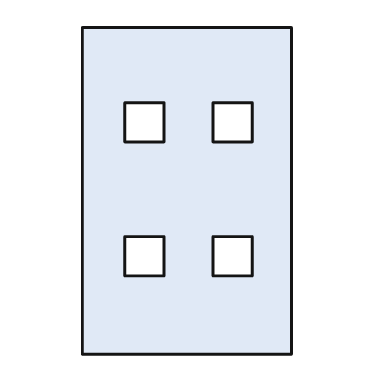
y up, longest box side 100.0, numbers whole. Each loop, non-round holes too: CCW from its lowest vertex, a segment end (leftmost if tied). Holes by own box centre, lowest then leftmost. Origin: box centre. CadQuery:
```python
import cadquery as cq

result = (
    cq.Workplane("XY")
    .moveTo(-32.0, -50.0)
    .lineTo(32.0, -50.0)
    .lineTo(32.0, 50.0)
    .lineTo(-32.0, 50.0)
    .close()
    .moveTo(-19.0, -26.0)
    .lineTo(-7.0, -26.0)
    .lineTo(-7.0, -14.0)
    .lineTo(-19.0, -14.0)
    .close()
    .moveTo(8.0, -26.0)
    .lineTo(20.0, -26.0)
    .lineTo(20.0, -14.0)
    .lineTo(8.0, -14.0)
    .close()
    .moveTo(-19.0, 15.0)
    .lineTo(-7.0, 15.0)
    .lineTo(-7.0, 27.0)
    .lineTo(-19.0, 27.0)
    .close()
    .moveTo(8.0, 15.0)
    .lineTo(20.0, 15.0)
    .lineTo(20.0, 27.0)
    .lineTo(8.0, 27.0)
    .close()
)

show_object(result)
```